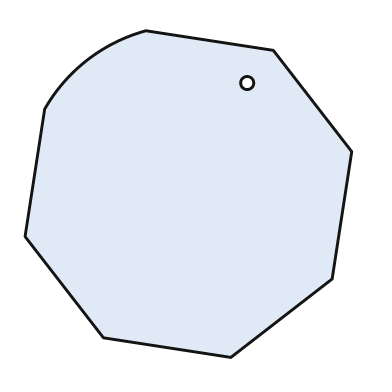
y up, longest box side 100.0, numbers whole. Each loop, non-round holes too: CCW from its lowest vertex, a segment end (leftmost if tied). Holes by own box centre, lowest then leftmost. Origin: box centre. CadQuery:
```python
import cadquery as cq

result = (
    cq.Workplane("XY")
    .moveTo(13.0, -50.0)
    .lineTo(44.0, -26.0)
    .lineTo(50.0, 13.0)
    .lineTo(26.0, 44.0)
    .lineTo(-13.0, 50.0)
    .threePointArc((-31.0, 41.0), (-44.0, 26.0))
    .lineTo(-50.0, -13.0)
    .lineTo(-26.0, -44.0)
    .close()
    .moveTo(18.0, 34.0)
    .circle(2.0)
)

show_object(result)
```